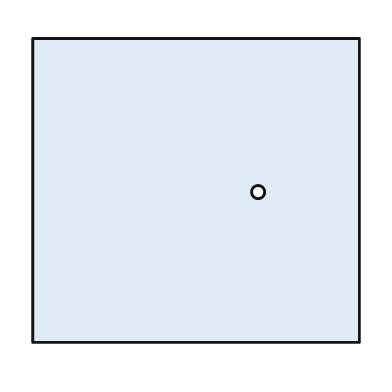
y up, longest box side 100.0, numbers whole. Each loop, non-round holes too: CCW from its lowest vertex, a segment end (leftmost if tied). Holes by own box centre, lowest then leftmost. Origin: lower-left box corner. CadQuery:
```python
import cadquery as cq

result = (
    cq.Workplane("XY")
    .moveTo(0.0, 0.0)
    .lineTo(100.0, 0.0)
    .lineTo(100.0, 93.0)
    .lineTo(0.0, 93.0)
    .close()
    .moveTo(69.0, 46.0)
    .circle(2.0)
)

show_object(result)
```